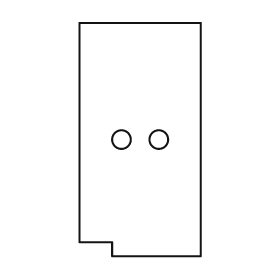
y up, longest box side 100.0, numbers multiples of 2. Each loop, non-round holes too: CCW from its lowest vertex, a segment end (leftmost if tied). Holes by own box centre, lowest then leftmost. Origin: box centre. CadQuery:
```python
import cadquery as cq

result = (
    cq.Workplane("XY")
    .moveTo(-12.0, -50.0)
    .lineTo(26.0, -50.0)
    .lineTo(26.0, 50.0)
    .lineTo(-26.0, 50.0)
    .lineTo(-26.0, -44.0)
    .lineTo(-12.0, -44.0)
    .close()
    .moveTo(-8.0, 0.0)
    .circle(4.0)
    .moveTo(8.0, 0.0)
    .circle(4.0)
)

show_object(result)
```